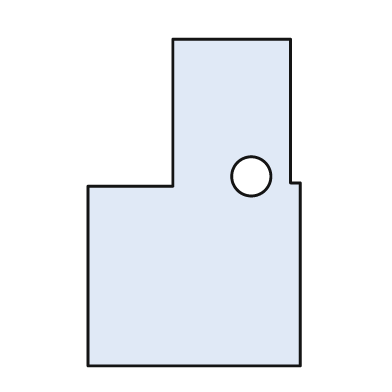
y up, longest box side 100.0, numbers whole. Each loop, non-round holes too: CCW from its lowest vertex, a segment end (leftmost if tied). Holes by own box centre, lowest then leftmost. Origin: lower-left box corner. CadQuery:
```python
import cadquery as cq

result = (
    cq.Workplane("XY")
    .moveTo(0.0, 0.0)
    .lineTo(65.0, 0.0)
    .lineTo(65.0, 56.0)
    .lineTo(62.0, 56.0)
    .lineTo(62.0, 100.0)
    .lineTo(26.0, 100.0)
    .lineTo(26.0, 55.0)
    .lineTo(0.0, 55.0)
    .close()
    .moveTo(50.0, 58.0)
    .circle(6.0)
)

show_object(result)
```